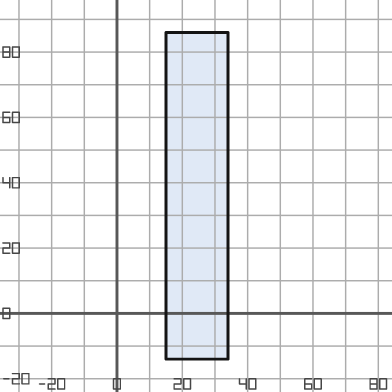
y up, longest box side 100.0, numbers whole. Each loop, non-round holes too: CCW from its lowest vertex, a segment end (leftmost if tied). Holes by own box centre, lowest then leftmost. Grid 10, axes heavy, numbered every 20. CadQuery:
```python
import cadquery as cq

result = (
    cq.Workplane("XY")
    .moveTo(15.0, -14.0)
    .lineTo(34.0, -14.0)
    .lineTo(34.0, 86.0)
    .lineTo(15.0, 86.0)
    .close()
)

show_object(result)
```